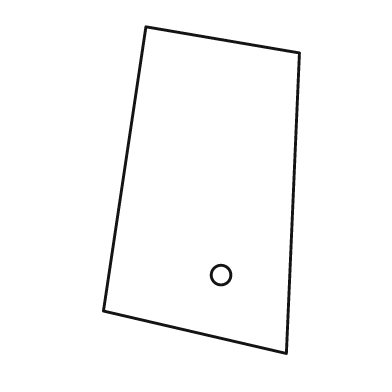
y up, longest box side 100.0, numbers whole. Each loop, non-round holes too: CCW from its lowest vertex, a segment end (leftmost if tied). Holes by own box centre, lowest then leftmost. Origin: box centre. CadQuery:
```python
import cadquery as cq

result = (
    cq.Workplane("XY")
    .moveTo(26.0, -50.0)
    .lineTo(30.0, 42.0)
    .lineTo(-17.0, 50.0)
    .lineTo(-30.0, -37.0)
    .close()
    .moveTo(6.0, -26.0)
    .circle(3.0)
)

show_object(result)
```